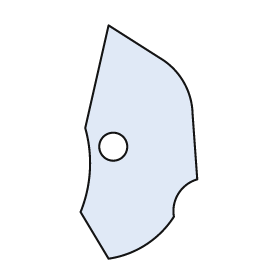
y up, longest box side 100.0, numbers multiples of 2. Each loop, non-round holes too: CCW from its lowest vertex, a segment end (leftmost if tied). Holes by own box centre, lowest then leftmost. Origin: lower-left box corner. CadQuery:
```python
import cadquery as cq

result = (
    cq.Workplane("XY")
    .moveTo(12.0, 0.0)
    .threePointArc((28.0, 6.0), (40.0, 18.0))
    .threePointArc((42.0, 28.0), (50.0, 34.0))
    .lineTo(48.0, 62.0)
    .threePointArc((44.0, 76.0), (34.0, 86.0))
    .lineTo(12.0, 100.0)
    .lineTo(2.0, 56.0)
    .threePointArc((4.0, 38.0), (0.0, 20.0))
    .close()
    .moveTo(14.0, 48.0)
    .circle(6.0)
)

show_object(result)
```